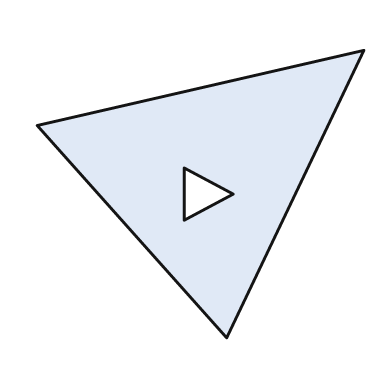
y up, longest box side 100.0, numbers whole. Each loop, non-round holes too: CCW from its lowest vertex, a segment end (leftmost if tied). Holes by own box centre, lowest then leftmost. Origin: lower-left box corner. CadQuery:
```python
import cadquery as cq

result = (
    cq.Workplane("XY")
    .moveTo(58.0, 0.0)
    .lineTo(100.0, 88.0)
    .lineTo(0.0, 65.0)
    .close()
    .moveTo(45.0, 36.0)
    .lineTo(60.0, 44.0)
    .lineTo(45.0, 52.0)
    .close()
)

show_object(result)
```